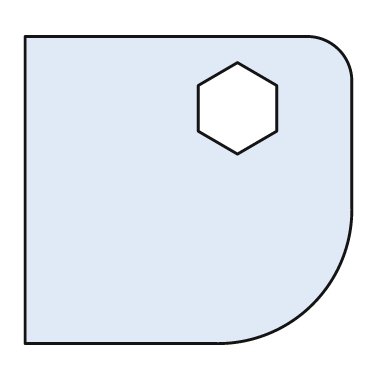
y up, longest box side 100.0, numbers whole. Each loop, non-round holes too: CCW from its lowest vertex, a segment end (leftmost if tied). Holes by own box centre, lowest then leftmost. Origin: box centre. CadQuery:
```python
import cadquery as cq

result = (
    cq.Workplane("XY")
    .moveTo(-50.0, -47.0)
    .lineTo(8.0, -47.0)
    .threePointArc((38.0, -35.0), (50.0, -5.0))
    .lineTo(50.0, 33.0)
    .threePointArc((46.0, 43.0), (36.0, 47.0))
    .lineTo(-50.0, 47.0)
    .close()
    .moveTo(15.0, 11.0)
    .lineTo(27.0, 18.0)
    .lineTo(27.0, 32.0)
    .lineTo(15.0, 39.0)
    .lineTo(3.0, 32.0)
    .lineTo(3.0, 18.0)
    .close()
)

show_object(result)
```